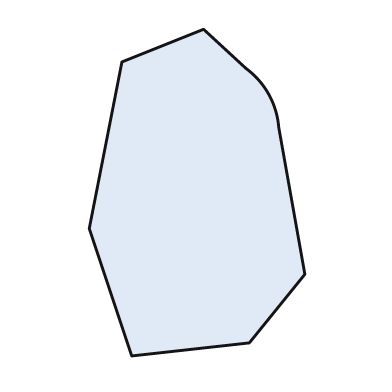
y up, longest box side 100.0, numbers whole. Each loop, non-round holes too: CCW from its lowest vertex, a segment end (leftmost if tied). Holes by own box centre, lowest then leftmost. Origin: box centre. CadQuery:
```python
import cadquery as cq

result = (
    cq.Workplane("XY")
    .moveTo(-20.0, -50.0)
    .lineTo(16.0, -46.0)
    .lineTo(33.0, -25.0)
    .lineTo(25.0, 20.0)
    .threePointArc((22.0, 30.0), (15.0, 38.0))
    .lineTo(2.0, 50.0)
    .lineTo(-23.0, 40.0)
    .lineTo(-33.0, -11.0)
    .close()
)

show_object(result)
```